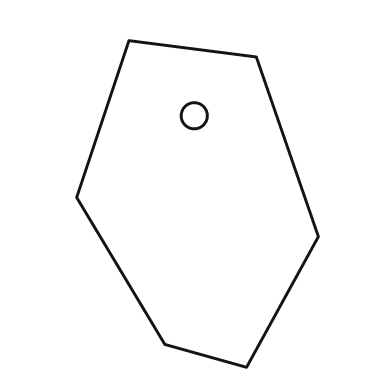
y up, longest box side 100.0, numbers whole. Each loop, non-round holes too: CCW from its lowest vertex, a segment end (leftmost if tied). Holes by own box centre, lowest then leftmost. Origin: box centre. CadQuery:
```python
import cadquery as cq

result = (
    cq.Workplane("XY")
    .moveTo(15.0, -50.0)
    .lineTo(37.0, -10.0)
    .lineTo(18.0, 45.0)
    .lineTo(-21.0, 50.0)
    .lineTo(-37.0, 2.0)
    .lineTo(-10.0, -43.0)
    .close()
    .moveTo(-1.0, 27.0)
    .circle(4.0)
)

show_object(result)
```